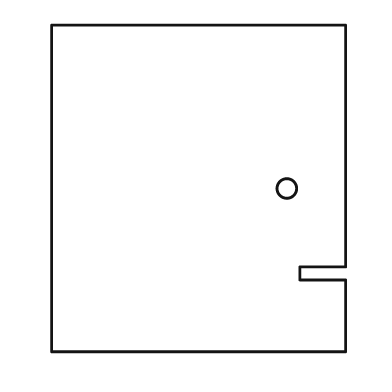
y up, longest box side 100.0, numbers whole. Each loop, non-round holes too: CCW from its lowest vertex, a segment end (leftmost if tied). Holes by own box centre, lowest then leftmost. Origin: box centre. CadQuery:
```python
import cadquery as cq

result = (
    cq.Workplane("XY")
    .moveTo(-45.0, -50.0)
    .lineTo(45.0, -50.0)
    .lineTo(45.0, -28.0)
    .lineTo(31.0, -28.0)
    .lineTo(31.0, -24.0)
    .lineTo(45.0, -24.0)
    .lineTo(45.0, 50.0)
    .lineTo(-45.0, 50.0)
    .close()
    .moveTo(27.0, 0.0)
    .circle(3.0)
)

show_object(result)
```